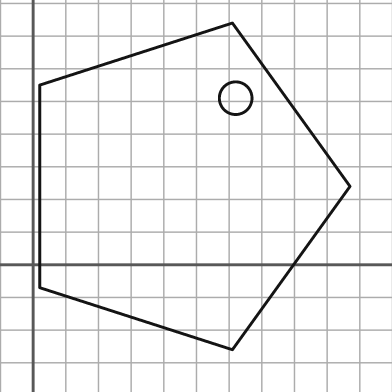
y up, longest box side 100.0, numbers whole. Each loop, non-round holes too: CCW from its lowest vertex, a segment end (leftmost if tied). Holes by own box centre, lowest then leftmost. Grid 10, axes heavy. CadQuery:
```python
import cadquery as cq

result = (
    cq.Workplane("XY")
    .moveTo(61.0, -26.0)
    .lineTo(97.0, 24.0)
    .lineTo(61.0, 74.0)
    .lineTo(2.0, 55.0)
    .lineTo(2.0, -7.0)
    .close()
    .moveTo(62.0, 51.0)
    .circle(5.0)
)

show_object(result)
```